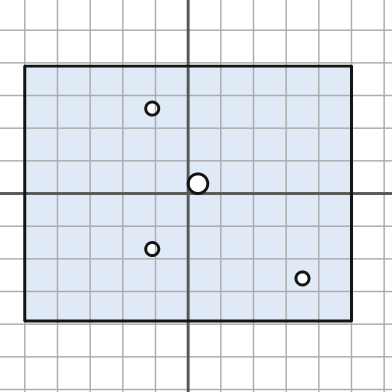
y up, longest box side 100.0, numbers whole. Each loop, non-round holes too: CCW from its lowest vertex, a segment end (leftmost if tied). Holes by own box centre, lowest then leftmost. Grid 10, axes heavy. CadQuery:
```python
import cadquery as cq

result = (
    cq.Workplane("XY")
    .moveTo(-50.0, -39.0)
    .lineTo(50.0, -39.0)
    .lineTo(50.0, 39.0)
    .lineTo(-50.0, 39.0)
    .close()
    .moveTo(35.0, -26.0)
    .circle(2.0)
    .moveTo(-11.0, -17.0)
    .circle(2.0)
    .moveTo(3.0, 3.0)
    .circle(3.0)
    .moveTo(-11.0, 26.0)
    .circle(2.0)
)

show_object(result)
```